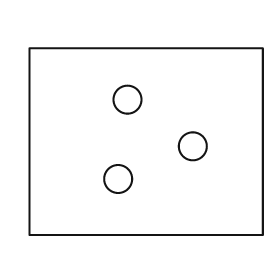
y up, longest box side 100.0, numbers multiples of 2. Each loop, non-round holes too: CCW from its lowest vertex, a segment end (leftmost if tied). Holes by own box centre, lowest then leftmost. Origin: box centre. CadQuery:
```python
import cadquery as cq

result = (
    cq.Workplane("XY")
    .moveTo(-50.0, -40.0)
    .lineTo(50.0, -40.0)
    .lineTo(50.0, 40.0)
    .lineTo(-50.0, 40.0)
    .close()
    .moveTo(-12.0, -16.0)
    .circle(6.0)
    .moveTo(20.0, -2.0)
    .circle(6.0)
    .moveTo(-8.0, 18.0)
    .circle(6.0)
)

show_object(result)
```